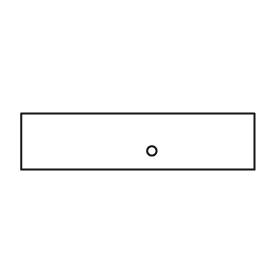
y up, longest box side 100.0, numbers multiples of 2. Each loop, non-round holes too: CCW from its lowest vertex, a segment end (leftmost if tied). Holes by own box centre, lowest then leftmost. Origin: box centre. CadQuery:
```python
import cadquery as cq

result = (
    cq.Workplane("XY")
    .moveTo(-50.0, -12.0)
    .lineTo(50.0, -12.0)
    .lineTo(50.0, 12.0)
    .lineTo(-50.0, 12.0)
    .close()
    .moveTo(6.0, -4.0)
    .circle(2.0)
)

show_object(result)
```